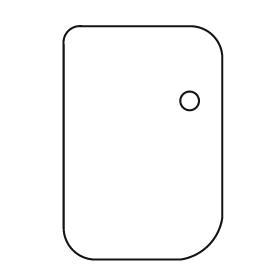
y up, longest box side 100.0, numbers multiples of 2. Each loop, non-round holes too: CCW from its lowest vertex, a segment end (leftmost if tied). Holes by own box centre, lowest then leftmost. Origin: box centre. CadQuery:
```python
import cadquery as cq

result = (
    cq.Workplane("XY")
    .moveTo(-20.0, -50.0)
    .lineTo(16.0, -50.0)
    .threePointArc((28.0, -44.0), (34.0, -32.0))
    .lineTo(34.0, 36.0)
    .threePointArc((30.0, 46.0), (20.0, 50.0))
    .lineTo(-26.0, 50.0)
    .threePointArc((-32.0, 48.0), (-34.0, 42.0))
    .lineTo(-34.0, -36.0)
    .threePointArc((-30.0, -46.0), (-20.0, -50.0))
    .close()
    .moveTo(20.0, 18.0)
    .circle(4.0)
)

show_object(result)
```